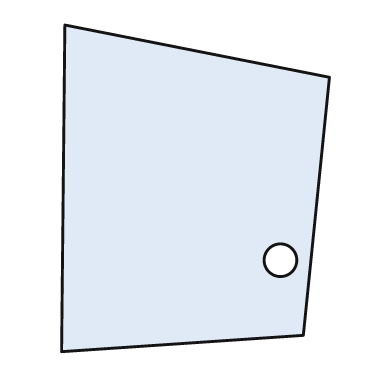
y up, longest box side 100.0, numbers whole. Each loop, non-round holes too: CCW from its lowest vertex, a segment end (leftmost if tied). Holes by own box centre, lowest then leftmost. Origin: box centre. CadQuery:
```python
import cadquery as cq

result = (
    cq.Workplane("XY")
    .moveTo(-41.0, -50.0)
    .lineTo(33.0, -45.0)
    .lineTo(41.0, 34.0)
    .lineTo(-40.0, 50.0)
    .close()
    .moveTo(26.0, -22.0)
    .circle(5.0)
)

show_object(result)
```